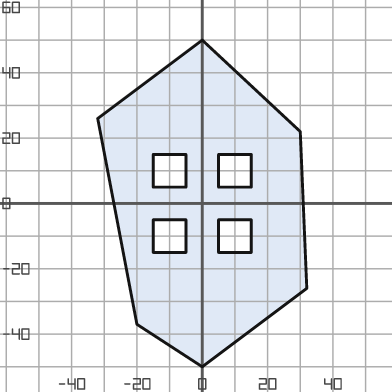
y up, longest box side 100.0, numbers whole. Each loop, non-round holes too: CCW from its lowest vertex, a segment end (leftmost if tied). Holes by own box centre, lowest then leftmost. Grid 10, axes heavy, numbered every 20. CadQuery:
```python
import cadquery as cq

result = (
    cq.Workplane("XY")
    .moveTo(0.0, -50.0)
    .lineTo(32.0, -26.0)
    .lineTo(30.0, 22.0)
    .lineTo(0.0, 50.0)
    .lineTo(-32.0, 26.0)
    .lineTo(-20.0, -37.0)
    .close()
    .moveTo(-15.0, -15.0)
    .lineTo(-5.0, -15.0)
    .lineTo(-5.0, -5.0)
    .lineTo(-15.0, -5.0)
    .close()
    .moveTo(5.0, -15.0)
    .lineTo(15.0, -15.0)
    .lineTo(15.0, -5.0)
    .lineTo(5.0, -5.0)
    .close()
    .moveTo(-15.0, 5.0)
    .lineTo(-5.0, 5.0)
    .lineTo(-5.0, 15.0)
    .lineTo(-15.0, 15.0)
    .close()
    .moveTo(5.0, 5.0)
    .lineTo(15.0, 5.0)
    .lineTo(15.0, 15.0)
    .lineTo(5.0, 15.0)
    .close()
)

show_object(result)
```